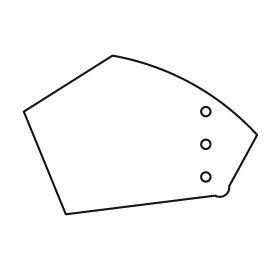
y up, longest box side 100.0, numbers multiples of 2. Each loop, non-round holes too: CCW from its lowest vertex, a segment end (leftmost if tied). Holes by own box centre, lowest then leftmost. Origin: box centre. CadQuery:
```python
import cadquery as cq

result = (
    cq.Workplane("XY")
    .moveTo(-32.0, -34.0)
    .lineTo(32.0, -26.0)
    .threePointArc((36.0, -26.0), (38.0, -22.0))
    .lineTo(50.0, 0.0)
    .threePointArc((22.0, 22.0), (-12.0, 34.0))
    .lineTo(-50.0, 10.0)
    .close()
    .moveTo(28.0, -18.0)
    .circle(2.0)
    .moveTo(28.0, -4.0)
    .circle(2.0)
    .moveTo(28.0, 10.0)
    .circle(2.0)
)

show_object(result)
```